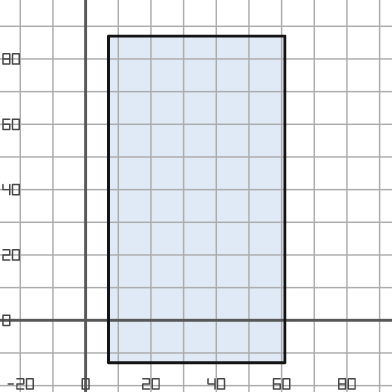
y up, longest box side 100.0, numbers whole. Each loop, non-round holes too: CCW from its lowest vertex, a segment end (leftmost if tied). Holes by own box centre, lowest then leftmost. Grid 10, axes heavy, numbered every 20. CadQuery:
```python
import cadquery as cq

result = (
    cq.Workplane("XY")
    .moveTo(7.0, -13.0)
    .lineTo(61.0, -13.0)
    .lineTo(61.0, 87.0)
    .lineTo(7.0, 87.0)
    .close()
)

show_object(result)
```